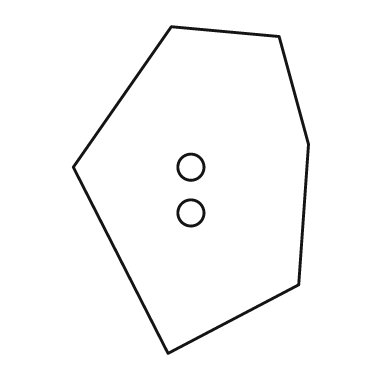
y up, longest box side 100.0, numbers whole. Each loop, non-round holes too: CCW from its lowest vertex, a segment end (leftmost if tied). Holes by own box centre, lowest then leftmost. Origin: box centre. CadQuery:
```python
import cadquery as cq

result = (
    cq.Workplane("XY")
    .moveTo(-7.0, -50.0)
    .lineTo(33.0, -29.0)
    .lineTo(36.0, 14.0)
    .lineTo(27.0, 47.0)
    .lineTo(-6.0, 50.0)
    .lineTo(-36.0, 7.0)
    .close()
    .moveTo(0.0, -7.0)
    .circle(4.0)
    .moveTo(0.0, 7.0)
    .circle(4.0)
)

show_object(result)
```